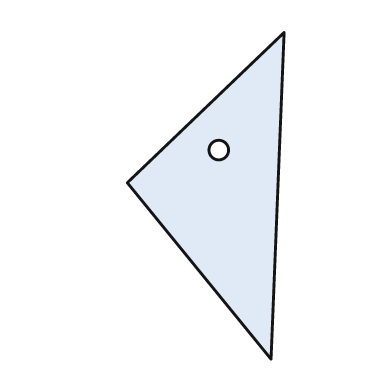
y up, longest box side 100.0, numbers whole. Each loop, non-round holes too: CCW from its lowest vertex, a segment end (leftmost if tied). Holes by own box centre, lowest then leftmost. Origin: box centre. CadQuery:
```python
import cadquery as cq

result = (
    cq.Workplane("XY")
    .moveTo(20.0, -50.0)
    .lineTo(24.0, 50.0)
    .lineTo(-24.0, 4.0)
    .close()
    .moveTo(4.0, 14.0)
    .circle(3.0)
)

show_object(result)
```